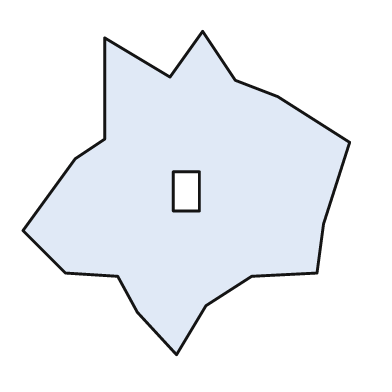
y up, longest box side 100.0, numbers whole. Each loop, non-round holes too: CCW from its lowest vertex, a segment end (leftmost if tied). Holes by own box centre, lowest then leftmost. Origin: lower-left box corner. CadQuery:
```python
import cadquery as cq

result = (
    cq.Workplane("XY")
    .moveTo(47.0, 0.0)
    .lineTo(56.0, 15.0)
    .lineTo(70.0, 24.0)
    .lineTo(90.0, 25.0)
    .lineTo(92.0, 40.0)
    .lineTo(100.0, 65.0)
    .lineTo(78.0, 79.0)
    .lineTo(65.0, 84.0)
    .lineTo(55.0, 99.0)
    .lineTo(45.0, 85.0)
    .lineTo(25.0, 97.0)
    .lineTo(25.0, 66.0)
    .lineTo(16.0, 60.0)
    .lineTo(0.0, 38.0)
    .lineTo(13.0, 25.0)
    .lineTo(29.0, 24.0)
    .lineTo(35.0, 13.0)
    .close()
    .moveTo(46.0, 44.0)
    .lineTo(54.0, 44.0)
    .lineTo(54.0, 56.0)
    .lineTo(46.0, 56.0)
    .close()
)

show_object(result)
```